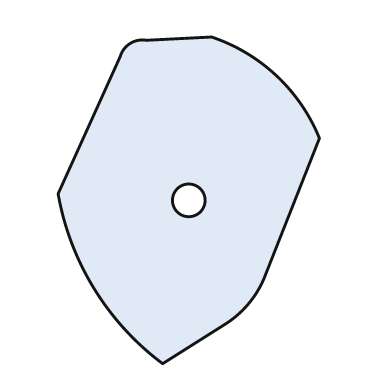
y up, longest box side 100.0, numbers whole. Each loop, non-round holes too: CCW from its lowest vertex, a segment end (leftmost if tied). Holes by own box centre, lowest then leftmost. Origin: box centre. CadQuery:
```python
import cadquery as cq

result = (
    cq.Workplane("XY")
    .moveTo(-8.0, -50.0)
    .lineTo(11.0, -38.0)
    .threePointArc((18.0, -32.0), (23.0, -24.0))
    .lineTo(40.0, 19.0)
    .threePointArc((27.0, 38.0), (7.0, 50.0))
    .lineTo(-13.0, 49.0)
    .threePointArc((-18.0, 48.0), (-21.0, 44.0))
    .lineTo(-40.0, 2.0)
    .threePointArc((-29.0, -27.0), (-8.0, -50.0))
    .close()
    .moveTo(0.0, 0.0)
    .circle(5.0)
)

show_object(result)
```